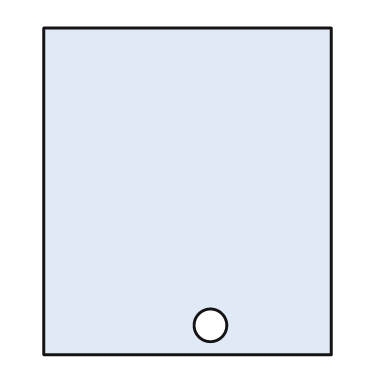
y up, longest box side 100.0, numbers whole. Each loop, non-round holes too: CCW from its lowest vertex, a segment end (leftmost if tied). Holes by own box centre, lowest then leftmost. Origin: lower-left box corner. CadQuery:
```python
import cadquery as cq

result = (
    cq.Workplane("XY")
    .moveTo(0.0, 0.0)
    .lineTo(88.0, 0.0)
    .lineTo(88.0, 100.0)
    .lineTo(0.0, 100.0)
    .close()
    .moveTo(51.0, 9.0)
    .circle(5.0)
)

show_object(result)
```